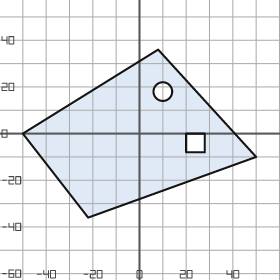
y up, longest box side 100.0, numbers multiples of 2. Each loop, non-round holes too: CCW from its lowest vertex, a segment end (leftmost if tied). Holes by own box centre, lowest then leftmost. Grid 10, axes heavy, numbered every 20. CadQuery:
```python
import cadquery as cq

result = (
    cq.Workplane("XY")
    .moveTo(-22.0, -36.0)
    .lineTo(50.0, -10.0)
    .lineTo(8.0, 36.0)
    .lineTo(-50.0, 0.0)
    .close()
    .moveTo(20.0, -8.0)
    .lineTo(28.0, -8.0)
    .lineTo(28.0, 0.0)
    .lineTo(20.0, 0.0)
    .close()
    .moveTo(10.0, 18.0)
    .circle(4.0)
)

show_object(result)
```